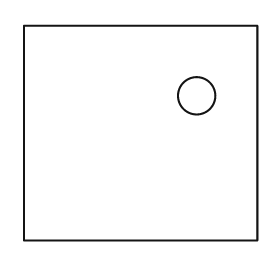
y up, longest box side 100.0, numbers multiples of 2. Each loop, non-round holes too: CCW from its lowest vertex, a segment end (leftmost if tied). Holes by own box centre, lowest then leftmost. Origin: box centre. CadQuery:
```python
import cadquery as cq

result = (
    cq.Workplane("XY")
    .moveTo(-50.0, -46.0)
    .lineTo(50.0, -46.0)
    .lineTo(50.0, 46.0)
    .lineTo(-50.0, 46.0)
    .close()
    .moveTo(24.0, 16.0)
    .circle(8.0)
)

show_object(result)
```